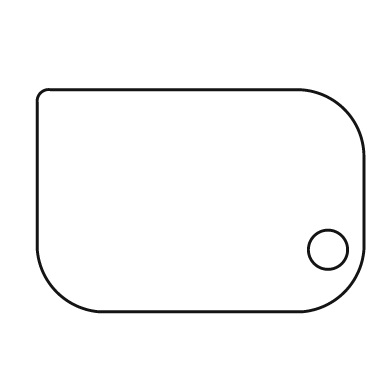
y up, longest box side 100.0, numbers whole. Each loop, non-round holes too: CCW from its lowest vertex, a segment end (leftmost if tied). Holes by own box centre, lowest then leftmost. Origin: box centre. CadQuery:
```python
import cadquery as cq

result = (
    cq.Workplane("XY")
    .moveTo(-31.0, -34.0)
    .lineTo(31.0, -34.0)
    .threePointArc((44.0, -28.0), (50.0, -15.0))
    .lineTo(50.0, 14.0)
    .threePointArc((44.0, 28.0), (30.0, 34.0))
    .lineTo(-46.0, 34.0)
    .threePointArc((-49.0, 33.0), (-50.0, 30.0))
    .lineTo(-50.0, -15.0)
    .threePointArc((-44.0, -28.0), (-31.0, -34.0))
    .close()
    .moveTo(39.0, -15.0)
    .circle(6.0)
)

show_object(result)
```